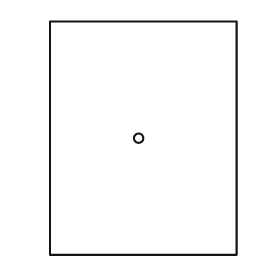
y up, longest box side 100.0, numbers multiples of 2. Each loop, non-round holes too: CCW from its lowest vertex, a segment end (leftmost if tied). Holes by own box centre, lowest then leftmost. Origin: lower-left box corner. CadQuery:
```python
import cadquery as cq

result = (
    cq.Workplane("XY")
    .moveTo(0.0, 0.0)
    .lineTo(80.0, 0.0)
    .lineTo(80.0, 100.0)
    .lineTo(0.0, 100.0)
    .close()
    .moveTo(38.0, 50.0)
    .circle(2.0)
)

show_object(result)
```